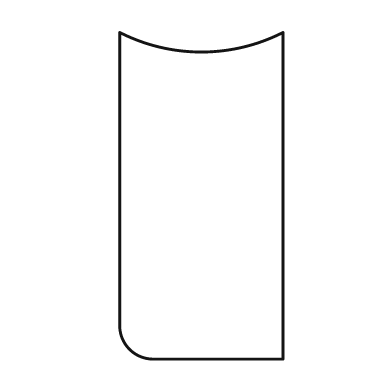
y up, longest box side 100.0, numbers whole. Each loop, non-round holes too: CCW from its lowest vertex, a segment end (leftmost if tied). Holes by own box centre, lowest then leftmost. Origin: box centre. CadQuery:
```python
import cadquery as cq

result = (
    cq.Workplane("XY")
    .moveTo(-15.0, -50.0)
    .lineTo(25.0, -50.0)
    .lineTo(25.0, 50.0)
    .threePointArc((0.0, 44.0), (-25.0, 50.0))
    .lineTo(-25.0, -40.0)
    .threePointArc((-22.0, -47.0), (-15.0, -50.0))
    .close()
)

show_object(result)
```